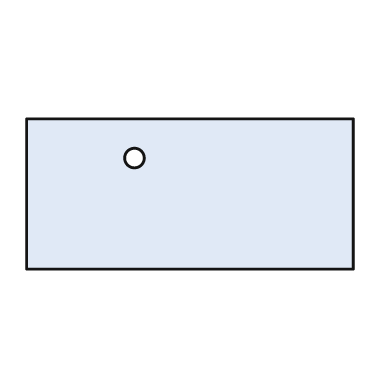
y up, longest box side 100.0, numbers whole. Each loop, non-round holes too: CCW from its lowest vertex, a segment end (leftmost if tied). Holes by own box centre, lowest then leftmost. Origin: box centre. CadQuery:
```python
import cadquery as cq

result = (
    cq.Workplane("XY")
    .moveTo(-50.0, -23.0)
    .lineTo(50.0, -23.0)
    .lineTo(50.0, 23.0)
    .lineTo(-50.0, 23.0)
    .close()
    .moveTo(-17.0, 11.0)
    .circle(3.0)
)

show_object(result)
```